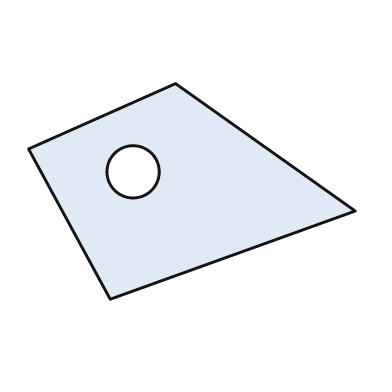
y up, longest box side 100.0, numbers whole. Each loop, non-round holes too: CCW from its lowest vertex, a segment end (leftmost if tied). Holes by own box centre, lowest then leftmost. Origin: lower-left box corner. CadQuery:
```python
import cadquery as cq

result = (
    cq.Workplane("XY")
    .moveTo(25.0, 0.0)
    .lineTo(100.0, 27.0)
    .lineTo(45.0, 66.0)
    .lineTo(0.0, 46.0)
    .close()
    .moveTo(32.0, 39.0)
    .circle(8.0)
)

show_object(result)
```